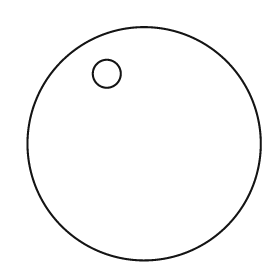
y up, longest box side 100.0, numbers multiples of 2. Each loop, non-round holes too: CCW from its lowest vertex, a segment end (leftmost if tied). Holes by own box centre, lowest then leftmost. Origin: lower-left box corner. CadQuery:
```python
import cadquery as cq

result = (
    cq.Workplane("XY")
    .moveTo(50.0, 50.0)
    .circle(50.0)
    .moveTo(34.0, 80.0)
    .circle(6.0)
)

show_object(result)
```